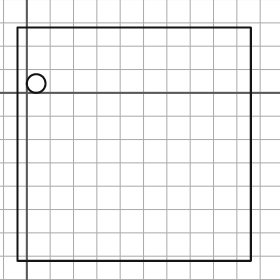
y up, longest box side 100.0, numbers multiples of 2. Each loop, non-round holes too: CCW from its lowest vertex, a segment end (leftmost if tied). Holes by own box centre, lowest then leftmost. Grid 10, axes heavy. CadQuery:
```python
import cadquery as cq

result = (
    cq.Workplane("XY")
    .moveTo(-4.0, -72.0)
    .lineTo(96.0, -72.0)
    .lineTo(96.0, 28.0)
    .lineTo(-4.0, 28.0)
    .close()
    .moveTo(4.0, 4.0)
    .circle(4.0)
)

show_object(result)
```